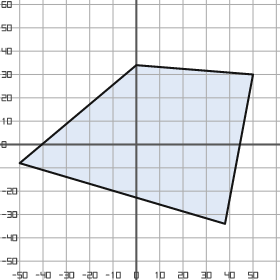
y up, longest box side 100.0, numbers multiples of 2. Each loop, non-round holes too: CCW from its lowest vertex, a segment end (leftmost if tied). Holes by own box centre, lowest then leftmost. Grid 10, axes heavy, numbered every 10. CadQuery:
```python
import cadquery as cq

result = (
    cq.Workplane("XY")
    .moveTo(38.0, -34.0)
    .lineTo(50.0, 30.0)
    .lineTo(0.0, 34.0)
    .lineTo(-50.0, -8.0)
    .close()
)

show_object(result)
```